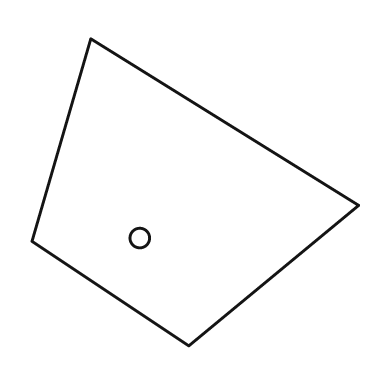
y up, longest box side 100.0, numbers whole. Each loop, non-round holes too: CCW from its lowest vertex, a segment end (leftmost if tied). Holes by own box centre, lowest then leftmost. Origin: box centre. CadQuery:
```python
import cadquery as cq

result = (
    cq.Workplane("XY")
    .moveTo(-2.0, -47.0)
    .lineTo(50.0, -4.0)
    .lineTo(-32.0, 47.0)
    .lineTo(-50.0, -15.0)
    .close()
    .moveTo(-17.0, -14.0)
    .circle(3.0)
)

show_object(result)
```